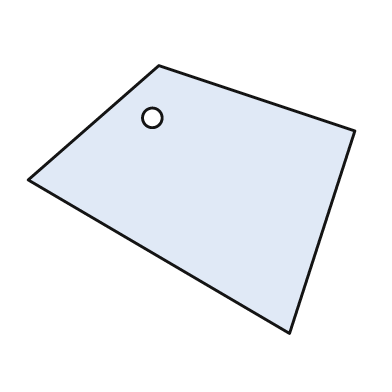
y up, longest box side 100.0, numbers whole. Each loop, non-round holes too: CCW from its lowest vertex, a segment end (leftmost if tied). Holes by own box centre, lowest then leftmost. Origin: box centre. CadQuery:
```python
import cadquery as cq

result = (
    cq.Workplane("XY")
    .moveTo(30.0, -41.0)
    .lineTo(50.0, 21.0)
    .lineTo(-10.0, 41.0)
    .lineTo(-50.0, 6.0)
    .close()
    .moveTo(-12.0, 25.0)
    .circle(3.0)
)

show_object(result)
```